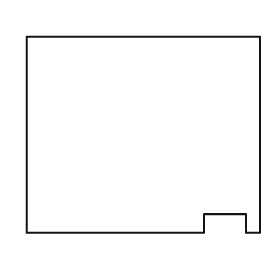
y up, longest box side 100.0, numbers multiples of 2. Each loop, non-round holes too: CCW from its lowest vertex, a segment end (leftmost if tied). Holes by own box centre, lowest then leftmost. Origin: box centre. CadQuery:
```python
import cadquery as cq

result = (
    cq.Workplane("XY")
    .moveTo(-50.0, -42.0)
    .lineTo(26.0, -42.0)
    .lineTo(26.0, -34.0)
    .lineTo(44.0, -34.0)
    .lineTo(44.0, -42.0)
    .lineTo(50.0, -42.0)
    .lineTo(50.0, 42.0)
    .lineTo(-50.0, 42.0)
    .close()
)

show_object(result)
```